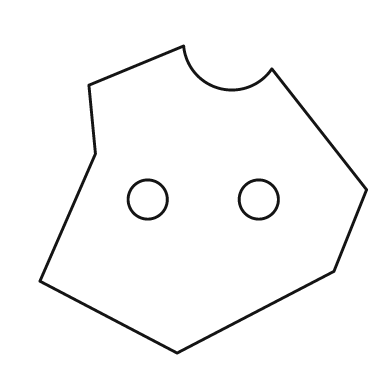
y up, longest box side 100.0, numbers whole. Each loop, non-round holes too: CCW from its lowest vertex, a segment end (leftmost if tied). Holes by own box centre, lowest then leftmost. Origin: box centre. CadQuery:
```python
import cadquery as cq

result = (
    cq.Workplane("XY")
    .moveTo(-8.0, -47.0)
    .lineTo(40.0, -22.0)
    .lineTo(50.0, 3.0)
    .lineTo(21.0, 40.0)
    .threePointArc((5.0, 34.0), (-6.0, 47.0))
    .lineTo(-35.0, 35.0)
    .lineTo(-33.0, 14.0)
    .lineTo(-50.0, -25.0)
    .close()
    .moveTo(-17.0, 0.0)
    .circle(6.0)
    .moveTo(17.0, 0.0)
    .circle(6.0)
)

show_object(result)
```